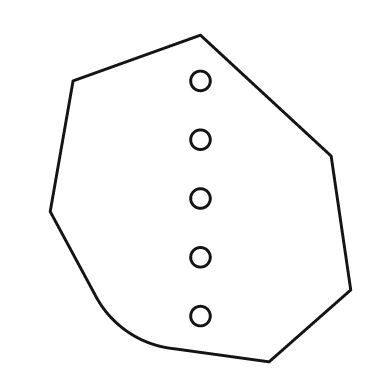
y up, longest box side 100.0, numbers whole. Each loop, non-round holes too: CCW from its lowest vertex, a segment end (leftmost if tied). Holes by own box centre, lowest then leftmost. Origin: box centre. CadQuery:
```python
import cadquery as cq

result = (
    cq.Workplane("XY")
    .moveTo(21.0, -50.0)
    .lineTo(46.0, -28.0)
    .lineTo(40.0, 13.0)
    .lineTo(0.0, 50.0)
    .lineTo(-39.0, 36.0)
    .lineTo(-46.0, -4.0)
    .lineTo(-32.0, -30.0)
    .threePointArc((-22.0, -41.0), (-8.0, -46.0))
    .close()
    .moveTo(0.0, -36.0)
    .circle(3.0)
    .moveTo(0.0, -18.0)
    .circle(3.0)
    .moveTo(0.0, 0.0)
    .circle(3.0)
    .moveTo(0.0, 18.0)
    .circle(3.0)
    .moveTo(0.0, 36.0)
    .circle(3.0)
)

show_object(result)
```